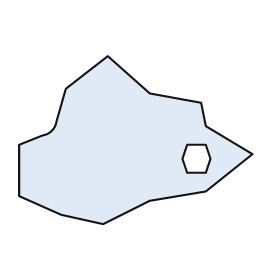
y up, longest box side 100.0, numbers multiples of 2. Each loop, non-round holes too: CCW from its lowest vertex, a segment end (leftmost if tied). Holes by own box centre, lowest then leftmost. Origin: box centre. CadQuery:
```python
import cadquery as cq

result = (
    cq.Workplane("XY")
    .moveTo(-14.0, -36.0)
    .lineTo(6.0, -26.0)
    .lineTo(30.0, -22.0)
    .lineTo(50.0, -6.0)
    .lineTo(30.0, 6.0)
    .lineTo(28.0, 16.0)
    .lineTo(6.0, 20.0)
    .lineTo(-12.0, 36.0)
    .lineTo(-30.0, 22.0)
    .lineTo(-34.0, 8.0)
    .threePointArc((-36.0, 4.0), (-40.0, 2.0))
    .lineTo(-50.0, -2.0)
    .lineTo(-50.0, -24.0)
    .lineTo(-32.0, -32.0)
    .close()
    .moveTo(22.0, -14.0)
    .lineTo(30.0, -14.0)
    .lineTo(32.0, -8.0)
    .lineTo(30.0, -2.0)
    .lineTo(22.0, -2.0)
    .lineTo(20.0, -8.0)
    .close()
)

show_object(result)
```